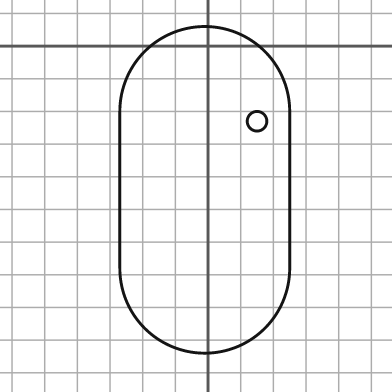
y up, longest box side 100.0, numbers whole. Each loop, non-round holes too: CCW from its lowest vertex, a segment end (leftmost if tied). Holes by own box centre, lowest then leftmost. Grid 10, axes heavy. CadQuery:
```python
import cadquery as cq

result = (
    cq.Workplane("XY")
    .moveTo(-27.0, -68.0)
    .threePointArc((-1.0, -94.0), (25.0, -68.0))
    .lineTo(25.0, -20.0)
    .threePointArc((-1.0, 6.0), (-27.0, -20.0))
    .close()
    .moveTo(15.0, -23.0)
    .circle(3.0)
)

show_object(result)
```